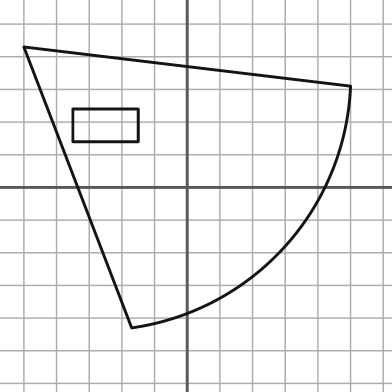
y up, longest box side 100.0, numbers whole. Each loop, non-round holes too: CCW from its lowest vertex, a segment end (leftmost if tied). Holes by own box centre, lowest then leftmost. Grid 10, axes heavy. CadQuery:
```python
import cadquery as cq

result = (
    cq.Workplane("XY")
    .moveTo(-17.0, -43.0)
    .threePointArc((30.0, -18.0), (50.0, 31.0))
    .lineTo(-50.0, 43.0)
    .close()
    .moveTo(-35.0, 14.0)
    .lineTo(-15.0, 14.0)
    .lineTo(-15.0, 24.0)
    .lineTo(-35.0, 24.0)
    .close()
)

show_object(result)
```